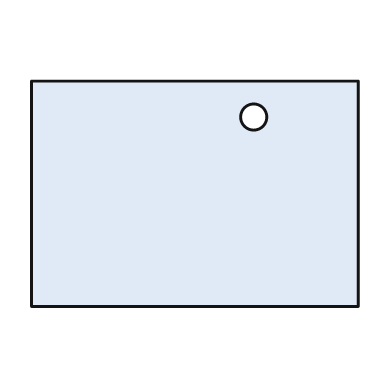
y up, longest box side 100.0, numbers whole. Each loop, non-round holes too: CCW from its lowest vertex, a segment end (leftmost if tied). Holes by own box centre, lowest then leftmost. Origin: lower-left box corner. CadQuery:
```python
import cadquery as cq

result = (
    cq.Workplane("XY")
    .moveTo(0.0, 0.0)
    .lineTo(100.0, 0.0)
    .lineTo(100.0, 69.0)
    .lineTo(0.0, 69.0)
    .close()
    .moveTo(68.0, 58.0)
    .circle(4.0)
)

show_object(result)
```